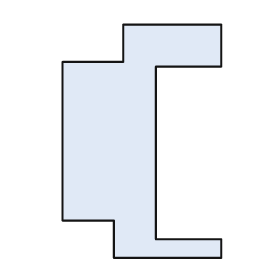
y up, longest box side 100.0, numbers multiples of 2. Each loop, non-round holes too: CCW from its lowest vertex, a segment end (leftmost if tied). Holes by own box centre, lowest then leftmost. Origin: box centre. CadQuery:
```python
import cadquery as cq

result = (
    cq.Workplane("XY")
    .moveTo(-12.0, -50.0)
    .lineTo(34.0, -50.0)
    .lineTo(34.0, -42.0)
    .lineTo(6.0, -42.0)
    .lineTo(6.0, 32.0)
    .lineTo(34.0, 32.0)
    .lineTo(34.0, 50.0)
    .lineTo(-8.0, 50.0)
    .lineTo(-8.0, 34.0)
    .lineTo(-34.0, 34.0)
    .lineTo(-34.0, -34.0)
    .lineTo(-12.0, -34.0)
    .close()
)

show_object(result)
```